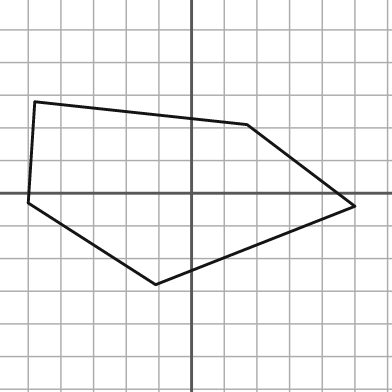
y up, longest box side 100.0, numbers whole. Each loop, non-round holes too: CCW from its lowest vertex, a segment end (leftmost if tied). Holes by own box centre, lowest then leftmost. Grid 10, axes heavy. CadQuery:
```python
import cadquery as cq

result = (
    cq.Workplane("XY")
    .moveTo(-11.0, -28.0)
    .lineTo(50.0, -4.0)
    .lineTo(17.0, 21.0)
    .lineTo(-48.0, 28.0)
    .lineTo(-50.0, -3.0)
    .close()
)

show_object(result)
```